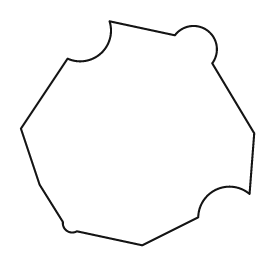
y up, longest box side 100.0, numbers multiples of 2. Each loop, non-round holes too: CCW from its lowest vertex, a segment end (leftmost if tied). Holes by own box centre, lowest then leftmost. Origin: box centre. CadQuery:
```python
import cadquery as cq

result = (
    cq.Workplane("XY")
    .moveTo(2.0, -48.0)
    .lineTo(26.0, -36.0)
    .threePointArc((34.0, -24.0), (48.0, -26.0))
    .lineTo(50.0, 0.0)
    .lineTo(32.0, 30.0)
    .threePointArc((30.0, 44.0), (16.0, 42.0))
    .lineTo(-12.0, 48.0)
    .threePointArc((-16.0, 34.0), (-30.0, 32.0))
    .lineTo(-50.0, 2.0)
    .lineTo(-42.0, -22.0)
    .lineTo(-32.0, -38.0)
    .threePointArc((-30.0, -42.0), (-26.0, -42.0))
    .close()
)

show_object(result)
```